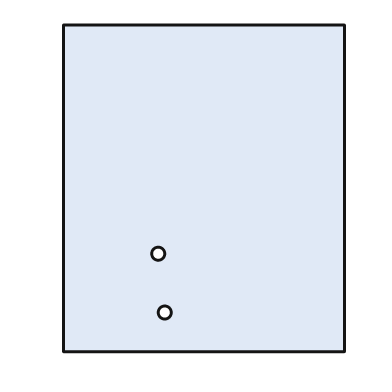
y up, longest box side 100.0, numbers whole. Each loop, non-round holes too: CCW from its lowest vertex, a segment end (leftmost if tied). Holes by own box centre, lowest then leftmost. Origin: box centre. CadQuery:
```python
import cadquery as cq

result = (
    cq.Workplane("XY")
    .moveTo(-43.0, -50.0)
    .lineTo(43.0, -50.0)
    .lineTo(43.0, 50.0)
    .lineTo(-43.0, 50.0)
    .close()
    .moveTo(-12.0, -38.0)
    .circle(2.0)
    .moveTo(-14.0, -20.0)
    .circle(2.0)
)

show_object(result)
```